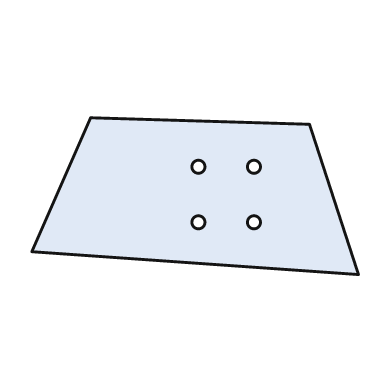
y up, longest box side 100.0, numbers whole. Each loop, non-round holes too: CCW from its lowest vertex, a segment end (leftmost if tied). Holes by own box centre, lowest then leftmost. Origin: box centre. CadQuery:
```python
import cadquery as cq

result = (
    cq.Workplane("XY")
    .moveTo(50.0, -24.0)
    .lineTo(35.0, 22.0)
    .lineTo(-32.0, 24.0)
    .lineTo(-50.0, -17.0)
    .close()
    .moveTo(1.0, -8.0)
    .circle(2.0)
    .moveTo(18.0, -8.0)
    .circle(2.0)
    .moveTo(1.0, 9.0)
    .circle(2.0)
    .moveTo(18.0, 9.0)
    .circle(2.0)
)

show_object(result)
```